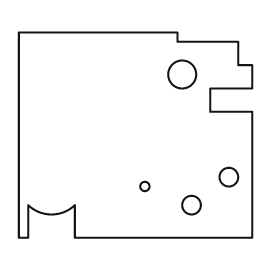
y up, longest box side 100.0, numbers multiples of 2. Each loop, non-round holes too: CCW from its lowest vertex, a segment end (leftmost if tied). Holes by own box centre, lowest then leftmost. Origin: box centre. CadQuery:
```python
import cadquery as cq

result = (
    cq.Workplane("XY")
    .moveTo(-50.0, -44.0)
    .lineTo(-46.0, -44.0)
    .lineTo(-46.0, -30.0)
    .threePointArc((-36.0, -34.0), (-26.0, -30.0))
    .lineTo(-26.0, -44.0)
    .lineTo(50.0, -44.0)
    .lineTo(50.0, 10.0)
    .lineTo(32.0, 10.0)
    .lineTo(32.0, 20.0)
    .lineTo(50.0, 20.0)
    .lineTo(50.0, 30.0)
    .lineTo(44.0, 30.0)
    .lineTo(44.0, 40.0)
    .lineTo(18.0, 40.0)
    .lineTo(18.0, 44.0)
    .lineTo(-50.0, 44.0)
    .close()
    .moveTo(24.0, -30.0)
    .circle(4.0)
    .moveTo(4.0, -22.0)
    .circle(2.0)
    .moveTo(40.0, -18.0)
    .circle(4.0)
    .moveTo(20.0, 26.0)
    .circle(6.0)
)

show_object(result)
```